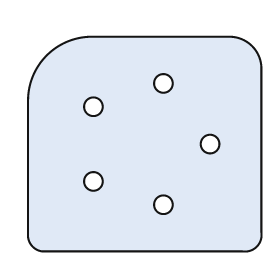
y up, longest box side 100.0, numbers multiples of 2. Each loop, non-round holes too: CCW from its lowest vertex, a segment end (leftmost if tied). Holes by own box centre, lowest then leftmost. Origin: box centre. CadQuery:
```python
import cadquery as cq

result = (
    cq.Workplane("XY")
    .moveTo(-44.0, -46.0)
    .lineTo(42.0, -46.0)
    .threePointArc((48.0, -44.0), (50.0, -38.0))
    .lineTo(50.0, 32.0)
    .threePointArc((46.0, 42.0), (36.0, 46.0))
    .lineTo(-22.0, 46.0)
    .threePointArc((-42.0, 38.0), (-50.0, 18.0))
    .lineTo(-50.0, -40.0)
    .threePointArc((-48.0, -44.0), (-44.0, -46.0))
    .close()
    .moveTo(8.0, -26.0)
    .circle(4.0)
    .moveTo(-22.0, -16.0)
    .circle(4.0)
    .moveTo(28.0, 0.0)
    .circle(4.0)
    .moveTo(-22.0, 16.0)
    .circle(4.0)
    .moveTo(8.0, 26.0)
    .circle(4.0)
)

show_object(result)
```